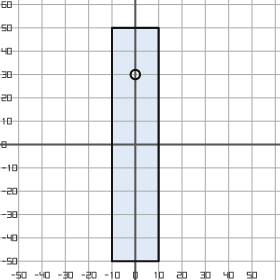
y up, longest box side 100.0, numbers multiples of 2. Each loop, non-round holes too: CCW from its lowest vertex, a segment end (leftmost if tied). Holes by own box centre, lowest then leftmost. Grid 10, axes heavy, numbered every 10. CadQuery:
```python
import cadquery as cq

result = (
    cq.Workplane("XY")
    .moveTo(-10.0, -50.0)
    .lineTo(10.0, -50.0)
    .lineTo(10.0, 50.0)
    .lineTo(-10.0, 50.0)
    .close()
    .moveTo(0.0, 30.0)
    .circle(2.0)
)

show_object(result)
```